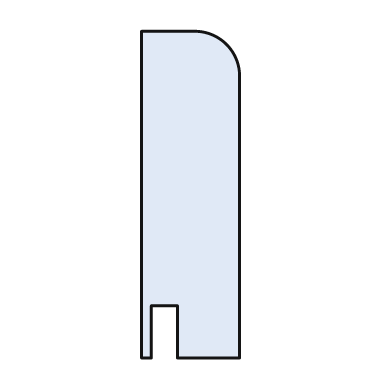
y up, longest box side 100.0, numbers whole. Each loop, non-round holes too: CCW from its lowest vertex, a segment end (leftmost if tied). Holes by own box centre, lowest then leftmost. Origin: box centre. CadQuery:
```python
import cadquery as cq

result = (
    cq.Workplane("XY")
    .moveTo(-15.0, -50.0)
    .lineTo(-12.0, -50.0)
    .lineTo(-12.0, -34.0)
    .lineTo(-4.0, -34.0)
    .lineTo(-4.0, -50.0)
    .lineTo(15.0, -50.0)
    .lineTo(15.0, 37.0)
    .threePointArc((11.0, 46.0), (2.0, 50.0))
    .lineTo(-15.0, 50.0)
    .close()
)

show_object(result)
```